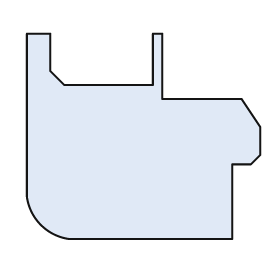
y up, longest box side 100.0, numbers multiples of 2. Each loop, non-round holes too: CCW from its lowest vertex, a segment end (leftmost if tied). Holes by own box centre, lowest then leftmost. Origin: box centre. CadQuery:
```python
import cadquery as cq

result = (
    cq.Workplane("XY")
    .moveTo(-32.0, -44.0)
    .lineTo(38.0, -44.0)
    .lineTo(38.0, -12.0)
    .lineTo(46.0, -12.0)
    .lineTo(50.0, -8.0)
    .lineTo(50.0, 4.0)
    .lineTo(42.0, 16.0)
    .lineTo(8.0, 16.0)
    .lineTo(8.0, 44.0)
    .lineTo(4.0, 44.0)
    .lineTo(4.0, 22.0)
    .lineTo(-34.0, 22.0)
    .lineTo(-40.0, 28.0)
    .lineTo(-40.0, 44.0)
    .lineTo(-50.0, 44.0)
    .lineTo(-50.0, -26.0)
    .threePointArc((-44.0, -38.0), (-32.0, -44.0))
    .close()
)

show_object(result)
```